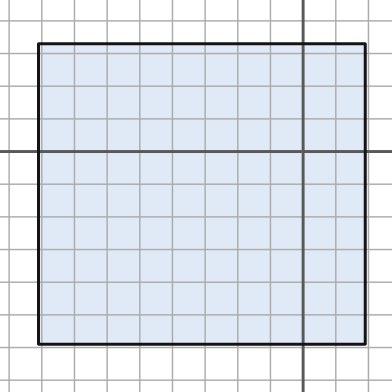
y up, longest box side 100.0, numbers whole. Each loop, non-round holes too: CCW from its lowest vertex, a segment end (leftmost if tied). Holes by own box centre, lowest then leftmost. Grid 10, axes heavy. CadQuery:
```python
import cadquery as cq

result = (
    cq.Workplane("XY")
    .moveTo(-81.0, -59.0)
    .lineTo(19.0, -59.0)
    .lineTo(19.0, 33.0)
    .lineTo(-81.0, 33.0)
    .close()
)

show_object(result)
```